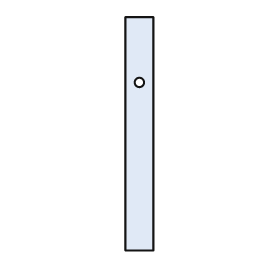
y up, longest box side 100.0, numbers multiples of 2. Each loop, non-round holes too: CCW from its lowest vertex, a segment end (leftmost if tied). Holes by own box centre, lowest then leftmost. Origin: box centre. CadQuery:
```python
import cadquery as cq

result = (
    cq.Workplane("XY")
    .moveTo(-6.0, -50.0)
    .lineTo(6.0, -50.0)
    .lineTo(6.0, 50.0)
    .lineTo(-6.0, 50.0)
    .close()
    .moveTo(0.0, 22.0)
    .circle(2.0)
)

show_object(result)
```